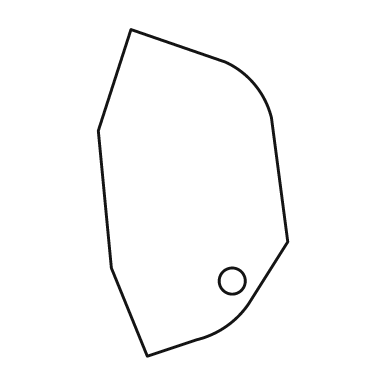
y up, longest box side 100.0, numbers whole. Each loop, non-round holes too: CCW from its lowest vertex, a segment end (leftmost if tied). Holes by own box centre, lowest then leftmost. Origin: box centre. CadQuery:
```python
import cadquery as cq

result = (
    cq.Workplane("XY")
    .moveTo(-14.0, -50.0)
    .lineTo(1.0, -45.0)
    .threePointArc((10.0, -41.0), (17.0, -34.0))
    .lineTo(29.0, -15.0)
    .lineTo(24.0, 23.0)
    .threePointArc((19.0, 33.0), (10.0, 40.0))
    .lineTo(-19.0, 50.0)
    .lineTo(-29.0, 19.0)
    .lineTo(-25.0, -23.0)
    .close()
    .moveTo(12.0, -27.0)
    .circle(4.0)
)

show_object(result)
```